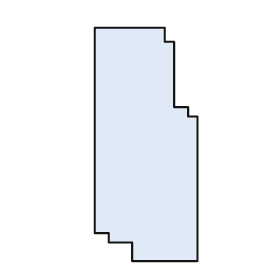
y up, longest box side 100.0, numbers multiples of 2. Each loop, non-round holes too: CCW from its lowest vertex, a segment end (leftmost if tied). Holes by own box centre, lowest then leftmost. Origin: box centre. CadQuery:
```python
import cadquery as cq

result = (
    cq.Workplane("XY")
    .moveTo(-6.0, -50.0)
    .lineTo(22.0, -50.0)
    .lineTo(22.0, 12.0)
    .lineTo(18.0, 12.0)
    .lineTo(18.0, 16.0)
    .lineTo(12.0, 16.0)
    .lineTo(12.0, 44.0)
    .lineTo(8.0, 44.0)
    .lineTo(8.0, 50.0)
    .lineTo(-22.0, 50.0)
    .lineTo(-22.0, -38.0)
    .lineTo(-16.0, -38.0)
    .lineTo(-16.0, -42.0)
    .lineTo(-6.0, -42.0)
    .close()
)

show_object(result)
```